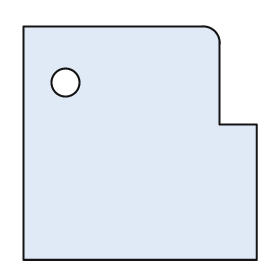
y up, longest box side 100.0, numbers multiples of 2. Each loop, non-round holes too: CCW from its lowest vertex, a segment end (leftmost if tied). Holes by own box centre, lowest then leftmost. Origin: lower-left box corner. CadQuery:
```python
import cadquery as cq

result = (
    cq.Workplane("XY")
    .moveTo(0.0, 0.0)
    .lineTo(100.0, 0.0)
    .lineTo(100.0, 58.0)
    .lineTo(84.0, 58.0)
    .lineTo(84.0, 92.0)
    .threePointArc((82.0, 98.0), (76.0, 100.0))
    .lineTo(0.0, 100.0)
    .close()
    .moveTo(18.0, 76.0)
    .circle(6.0)
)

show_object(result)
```